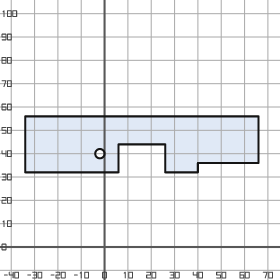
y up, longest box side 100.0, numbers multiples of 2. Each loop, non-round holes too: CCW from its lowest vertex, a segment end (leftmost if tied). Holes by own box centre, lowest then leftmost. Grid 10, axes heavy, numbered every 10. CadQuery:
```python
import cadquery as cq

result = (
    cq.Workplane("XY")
    .moveTo(-34.0, 32.0)
    .lineTo(6.0, 32.0)
    .lineTo(6.0, 44.0)
    .lineTo(26.0, 44.0)
    .lineTo(26.0, 32.0)
    .lineTo(40.0, 32.0)
    .lineTo(40.0, 36.0)
    .lineTo(66.0, 36.0)
    .lineTo(66.0, 56.0)
    .lineTo(-34.0, 56.0)
    .close()
    .moveTo(-2.0, 40.0)
    .circle(2.0)
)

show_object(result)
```